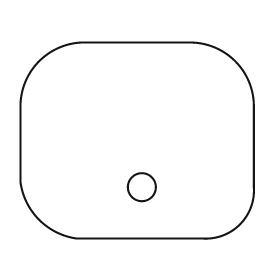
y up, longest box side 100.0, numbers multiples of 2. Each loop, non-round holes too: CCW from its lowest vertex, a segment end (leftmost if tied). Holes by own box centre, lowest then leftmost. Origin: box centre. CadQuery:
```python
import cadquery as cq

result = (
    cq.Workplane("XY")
    .moveTo(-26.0, -42.0)
    .lineTo(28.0, -42.0)
    .threePointArc((44.0, -36.0), (50.0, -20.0))
    .lineTo(50.0, 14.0)
    .threePointArc((42.0, 34.0), (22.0, 42.0))
    .lineTo(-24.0, 42.0)
    .threePointArc((-42.0, 34.0), (-50.0, 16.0))
    .lineTo(-50.0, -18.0)
    .threePointArc((-42.0, -34.0), (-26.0, -42.0))
    .close()
    .moveTo(2.0, -20.0)
    .circle(6.0)
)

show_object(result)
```